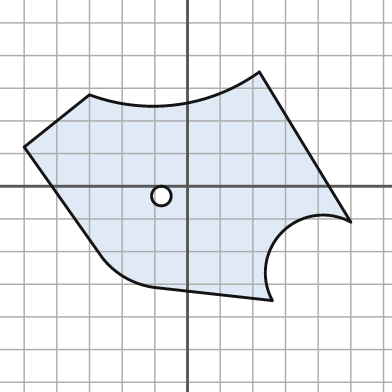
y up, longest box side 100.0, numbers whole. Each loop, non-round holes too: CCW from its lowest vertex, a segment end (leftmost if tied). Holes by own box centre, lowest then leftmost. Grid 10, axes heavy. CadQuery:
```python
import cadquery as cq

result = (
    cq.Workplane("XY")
    .moveTo(26.0, -35.0)
    .threePointArc((29.0, -14.0), (50.0, -11.0))
    .lineTo(22.0, 35.0)
    .threePointArc((-3.0, 25.0), (-30.0, 28.0))
    .lineTo(-50.0, 12.0)
    .lineTo(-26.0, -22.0)
    .threePointArc((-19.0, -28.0), (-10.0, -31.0))
    .close()
    .moveTo(-8.0, -3.0)
    .circle(3.0)
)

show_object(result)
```